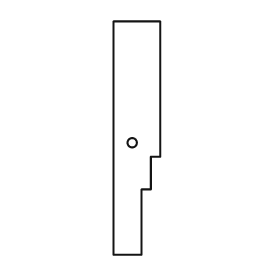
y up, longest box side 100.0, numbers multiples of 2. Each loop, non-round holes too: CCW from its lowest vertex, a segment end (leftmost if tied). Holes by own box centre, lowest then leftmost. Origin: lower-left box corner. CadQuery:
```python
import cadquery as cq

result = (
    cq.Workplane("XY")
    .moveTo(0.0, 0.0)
    .lineTo(12.0, 0.0)
    .lineTo(12.0, 28.0)
    .lineTo(16.0, 28.0)
    .lineTo(16.0, 42.0)
    .lineTo(20.0, 42.0)
    .lineTo(20.0, 100.0)
    .lineTo(0.0, 100.0)
    .close()
    .moveTo(8.0, 48.0)
    .circle(2.0)
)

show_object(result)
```